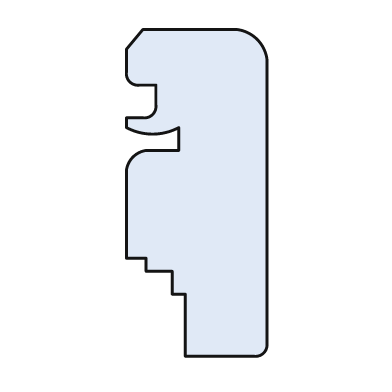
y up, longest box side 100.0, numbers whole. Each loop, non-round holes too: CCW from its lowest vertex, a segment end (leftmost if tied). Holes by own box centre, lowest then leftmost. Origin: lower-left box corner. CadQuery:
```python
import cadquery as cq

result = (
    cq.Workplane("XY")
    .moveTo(18.0, 0.0)
    .lineTo(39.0, 0.0)
    .threePointArc((42.0, 1.0), (43.0, 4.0))
    .lineTo(43.0, 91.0)
    .threePointArc((40.0, 97.0), (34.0, 100.0))
    .lineTo(5.0, 100.0)
    .lineTo(0.0, 94.0)
    .lineTo(0.0, 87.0)
    .threePointArc((1.0, 84.0), (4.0, 83.0))
    .lineTo(9.0, 83.0)
    .lineTo(9.0, 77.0)
    .threePointArc((8.0, 74.0), (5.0, 73.0))
    .lineTo(0.0, 73.0)
    .lineTo(0.0, 70.0)
    .threePointArc((8.0, 68.0), (16.0, 70.0))
    .lineTo(16.0, 63.0)
    .lineTo(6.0, 63.0)
    .threePointArc((2.0, 61.0), (0.0, 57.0))
    .lineTo(0.0, 30.0)
    .lineTo(6.0, 30.0)
    .lineTo(6.0, 26.0)
    .lineTo(14.0, 26.0)
    .lineTo(14.0, 19.0)
    .lineTo(18.0, 19.0)
    .close()
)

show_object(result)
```